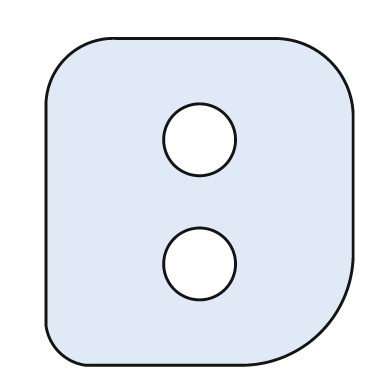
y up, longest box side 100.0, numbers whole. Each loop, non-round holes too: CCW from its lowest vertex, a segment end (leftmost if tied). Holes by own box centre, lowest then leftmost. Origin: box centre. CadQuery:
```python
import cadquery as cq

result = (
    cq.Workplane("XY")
    .moveTo(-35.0, -50.0)
    .lineTo(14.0, -50.0)
    .threePointArc((37.0, -40.0), (47.0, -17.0))
    .lineTo(47.0, 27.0)
    .threePointArc((40.0, 43.0), (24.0, 50.0))
    .lineTo(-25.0, 50.0)
    .threePointArc((-41.0, 44.0), (-47.0, 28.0))
    .lineTo(-47.0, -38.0)
    .threePointArc((-43.0, -46.0), (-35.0, -50.0))
    .close()
    .moveTo(0.0, -19.0)
    .circle(11.0)
    .moveTo(0.0, 19.0)
    .circle(11.0)
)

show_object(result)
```